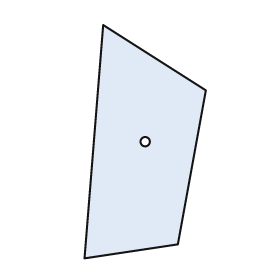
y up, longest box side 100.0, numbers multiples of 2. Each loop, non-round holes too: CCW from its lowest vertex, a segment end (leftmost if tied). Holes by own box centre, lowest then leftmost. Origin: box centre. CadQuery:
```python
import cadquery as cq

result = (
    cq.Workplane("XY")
    .moveTo(-26.0, -50.0)
    .lineTo(14.0, -44.0)
    .lineTo(26.0, 22.0)
    .lineTo(-18.0, 50.0)
    .close()
    .moveTo(0.0, 0.0)
    .circle(2.0)
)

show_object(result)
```